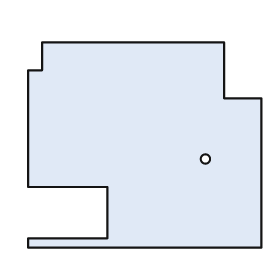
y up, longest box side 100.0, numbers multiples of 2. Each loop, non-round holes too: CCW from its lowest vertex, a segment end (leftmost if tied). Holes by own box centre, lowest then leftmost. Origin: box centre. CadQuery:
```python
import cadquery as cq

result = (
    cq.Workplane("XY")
    .moveTo(-50.0, -44.0)
    .lineTo(50.0, -44.0)
    .lineTo(50.0, 20.0)
    .lineTo(34.0, 20.0)
    .lineTo(34.0, 44.0)
    .lineTo(-44.0, 44.0)
    .lineTo(-44.0, 32.0)
    .lineTo(-50.0, 32.0)
    .lineTo(-50.0, -18.0)
    .lineTo(-16.0, -18.0)
    .lineTo(-16.0, -40.0)
    .lineTo(-50.0, -40.0)
    .close()
    .moveTo(26.0, -6.0)
    .circle(2.0)
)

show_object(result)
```